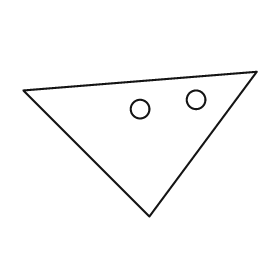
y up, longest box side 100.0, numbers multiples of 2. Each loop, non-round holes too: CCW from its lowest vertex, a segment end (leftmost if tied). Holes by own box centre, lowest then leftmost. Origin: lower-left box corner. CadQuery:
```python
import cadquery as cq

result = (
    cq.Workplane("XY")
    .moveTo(54.0, 0.0)
    .lineTo(100.0, 62.0)
    .lineTo(0.0, 54.0)
    .close()
    .moveTo(50.0, 46.0)
    .circle(4.0)
    .moveTo(74.0, 50.0)
    .circle(4.0)
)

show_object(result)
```